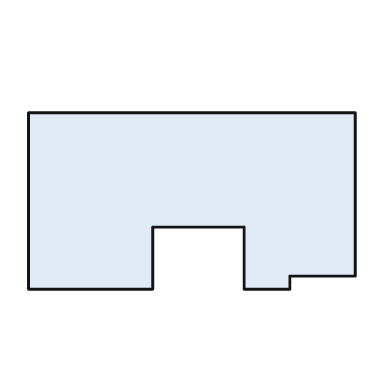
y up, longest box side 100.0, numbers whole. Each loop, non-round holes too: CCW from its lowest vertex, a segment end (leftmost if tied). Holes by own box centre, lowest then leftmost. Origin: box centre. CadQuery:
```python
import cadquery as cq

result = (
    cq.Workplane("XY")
    .moveTo(-50.0, -27.0)
    .lineTo(-12.0, -27.0)
    .lineTo(-12.0, -8.0)
    .lineTo(16.0, -8.0)
    .lineTo(16.0, -27.0)
    .lineTo(30.0, -27.0)
    .lineTo(30.0, -23.0)
    .lineTo(50.0, -23.0)
    .lineTo(50.0, 27.0)
    .lineTo(-50.0, 27.0)
    .close()
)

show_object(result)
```